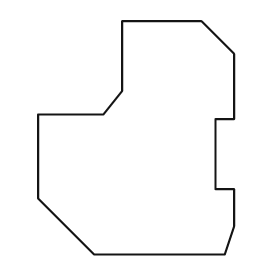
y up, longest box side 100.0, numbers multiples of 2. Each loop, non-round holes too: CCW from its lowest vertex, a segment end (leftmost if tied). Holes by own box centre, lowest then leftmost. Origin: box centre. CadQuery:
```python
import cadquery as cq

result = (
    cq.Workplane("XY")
    .moveTo(-18.0, -50.0)
    .lineTo(38.0, -50.0)
    .lineTo(42.0, -38.0)
    .lineTo(42.0, -22.0)
    .lineTo(34.0, -22.0)
    .lineTo(34.0, 8.0)
    .lineTo(42.0, 8.0)
    .lineTo(42.0, 36.0)
    .lineTo(28.0, 50.0)
    .lineTo(-6.0, 50.0)
    .lineTo(-6.0, 20.0)
    .lineTo(-14.0, 10.0)
    .lineTo(-42.0, 10.0)
    .lineTo(-42.0, -26.0)
    .close()
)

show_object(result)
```